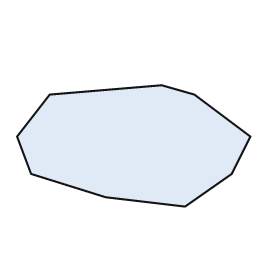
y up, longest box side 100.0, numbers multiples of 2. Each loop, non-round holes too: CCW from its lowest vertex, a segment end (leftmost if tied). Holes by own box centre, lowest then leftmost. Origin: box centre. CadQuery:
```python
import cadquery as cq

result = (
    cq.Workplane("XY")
    .moveTo(22.0, -26.0)
    .lineTo(42.0, -12.0)
    .lineTo(50.0, 4.0)
    .lineTo(26.0, 22.0)
    .lineTo(12.0, 26.0)
    .lineTo(-36.0, 22.0)
    .lineTo(-50.0, 4.0)
    .lineTo(-44.0, -12.0)
    .lineTo(-12.0, -22.0)
    .close()
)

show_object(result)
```